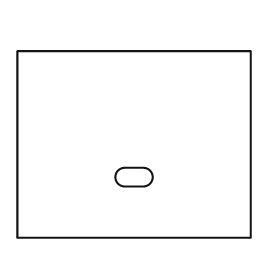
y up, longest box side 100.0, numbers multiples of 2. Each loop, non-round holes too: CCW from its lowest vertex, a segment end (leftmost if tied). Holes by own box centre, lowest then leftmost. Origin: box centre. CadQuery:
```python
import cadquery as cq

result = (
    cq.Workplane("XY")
    .moveTo(-50.0, -40.0)
    .lineTo(50.0, -40.0)
    .lineTo(50.0, 40.0)
    .lineTo(-50.0, 40.0)
    .close()
    .moveTo(-4.0, -18.0)
    .lineTo(4.0, -18.0)
    .threePointArc((8.0, -14.0), (4.0, -10.0))
    .lineTo(-4.0, -10.0)
    .threePointArc((-8.0, -14.0), (-4.0, -18.0))
    .close()
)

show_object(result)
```